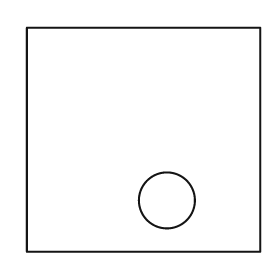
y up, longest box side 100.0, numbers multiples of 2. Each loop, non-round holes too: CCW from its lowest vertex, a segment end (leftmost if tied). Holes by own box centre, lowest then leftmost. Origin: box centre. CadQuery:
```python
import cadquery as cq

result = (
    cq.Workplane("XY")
    .moveTo(-50.0, -48.0)
    .lineTo(50.0, -48.0)
    .lineTo(50.0, 48.0)
    .lineTo(-50.0, 48.0)
    .close()
    .moveTo(10.0, -26.0)
    .circle(12.0)
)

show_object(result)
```